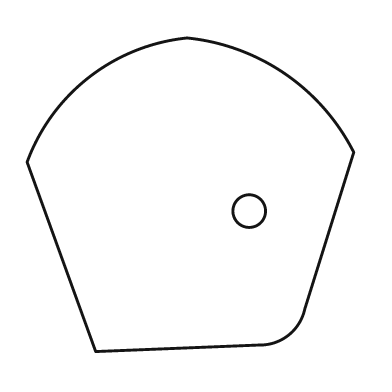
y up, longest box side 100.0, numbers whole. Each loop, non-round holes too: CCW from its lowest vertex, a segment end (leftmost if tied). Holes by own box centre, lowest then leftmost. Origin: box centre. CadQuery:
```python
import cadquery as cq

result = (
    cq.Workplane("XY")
    .moveTo(-29.0, -48.0)
    .lineTo(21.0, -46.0)
    .threePointArc((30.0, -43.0), (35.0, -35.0))
    .lineTo(50.0, 13.0)
    .threePointArc((29.0, 37.0), (-1.0, 48.0))
    .threePointArc((-31.0, 36.0), (-50.0, 10.0))
    .close()
    .moveTo(18.0, -5.0)
    .circle(5.0)
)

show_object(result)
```